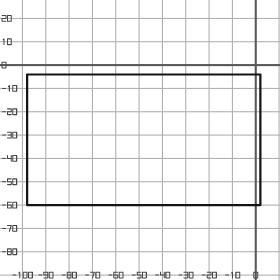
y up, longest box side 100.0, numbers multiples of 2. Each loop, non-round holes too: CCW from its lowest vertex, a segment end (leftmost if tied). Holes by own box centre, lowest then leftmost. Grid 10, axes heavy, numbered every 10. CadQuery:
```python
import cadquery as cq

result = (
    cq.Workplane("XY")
    .moveTo(-98.0, -60.0)
    .lineTo(2.0, -60.0)
    .lineTo(2.0, -4.0)
    .lineTo(-98.0, -4.0)
    .close()
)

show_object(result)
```